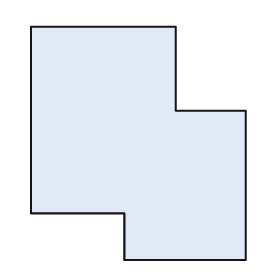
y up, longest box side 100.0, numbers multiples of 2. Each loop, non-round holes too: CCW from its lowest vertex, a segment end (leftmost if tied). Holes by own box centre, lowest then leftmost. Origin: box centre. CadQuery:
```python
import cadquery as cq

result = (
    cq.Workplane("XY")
    .moveTo(-6.0, -50.0)
    .lineTo(46.0, -50.0)
    .lineTo(46.0, 14.0)
    .lineTo(16.0, 14.0)
    .lineTo(16.0, 50.0)
    .lineTo(-46.0, 50.0)
    .lineTo(-46.0, -30.0)
    .lineTo(-6.0, -30.0)
    .close()
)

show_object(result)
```